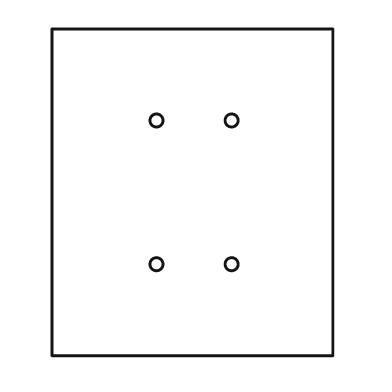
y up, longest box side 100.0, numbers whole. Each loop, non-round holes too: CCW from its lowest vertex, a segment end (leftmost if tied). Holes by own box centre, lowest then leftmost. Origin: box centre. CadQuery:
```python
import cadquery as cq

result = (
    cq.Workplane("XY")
    .moveTo(-43.0, -50.0)
    .lineTo(43.0, -50.0)
    .lineTo(43.0, 50.0)
    .lineTo(-43.0, 50.0)
    .close()
    .moveTo(-11.0, -22.0)
    .circle(2.0)
    .moveTo(12.0, -22.0)
    .circle(2.0)
    .moveTo(-11.0, 22.0)
    .circle(2.0)
    .moveTo(12.0, 22.0)
    .circle(2.0)
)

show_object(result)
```